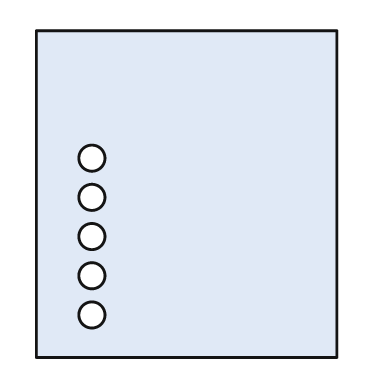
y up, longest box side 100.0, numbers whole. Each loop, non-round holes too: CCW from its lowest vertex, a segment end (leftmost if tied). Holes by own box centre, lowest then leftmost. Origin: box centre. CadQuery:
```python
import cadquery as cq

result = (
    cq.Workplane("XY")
    .moveTo(-46.0, -50.0)
    .lineTo(46.0, -50.0)
    .lineTo(46.0, 50.0)
    .lineTo(-46.0, 50.0)
    .close()
    .moveTo(-29.0, -37.0)
    .circle(4.0)
    .moveTo(-29.0, -25.0)
    .circle(4.0)
    .moveTo(-29.0, -13.0)
    .circle(4.0)
    .moveTo(-29.0, -1.0)
    .circle(4.0)
    .moveTo(-29.0, 11.0)
    .circle(4.0)
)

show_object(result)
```